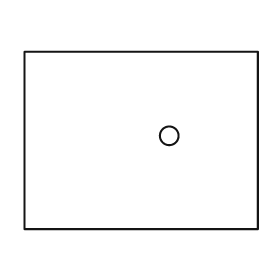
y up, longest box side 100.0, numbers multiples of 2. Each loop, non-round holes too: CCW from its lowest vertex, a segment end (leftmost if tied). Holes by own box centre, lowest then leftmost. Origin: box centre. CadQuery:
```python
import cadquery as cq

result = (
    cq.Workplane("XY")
    .moveTo(-50.0, -38.0)
    .lineTo(50.0, -38.0)
    .lineTo(50.0, 38.0)
    .lineTo(-50.0, 38.0)
    .close()
    .moveTo(12.0, 2.0)
    .circle(4.0)
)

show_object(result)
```